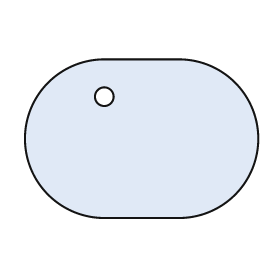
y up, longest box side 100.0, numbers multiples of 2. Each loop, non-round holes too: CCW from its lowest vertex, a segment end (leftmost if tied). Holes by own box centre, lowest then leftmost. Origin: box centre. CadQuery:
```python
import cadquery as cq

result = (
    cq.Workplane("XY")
    .moveTo(-16.0, -34.0)
    .lineTo(16.0, -34.0)
    .threePointArc((50.0, 0.0), (16.0, 34.0))
    .lineTo(-16.0, 34.0)
    .threePointArc((-50.0, 0.0), (-16.0, -34.0))
    .close()
    .moveTo(-16.0, 18.0)
    .circle(4.0)
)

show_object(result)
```